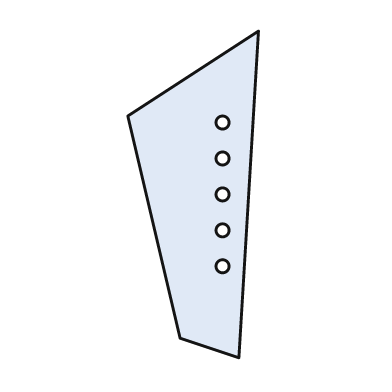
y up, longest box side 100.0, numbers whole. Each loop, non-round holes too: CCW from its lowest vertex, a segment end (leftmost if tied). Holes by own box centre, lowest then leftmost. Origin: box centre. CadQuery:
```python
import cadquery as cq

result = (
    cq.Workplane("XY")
    .moveTo(14.0, -50.0)
    .lineTo(20.0, 50.0)
    .lineTo(-20.0, 24.0)
    .lineTo(-4.0, -44.0)
    .close()
    .moveTo(9.0, -22.0)
    .circle(2.0)
    .moveTo(9.0, -11.0)
    .circle(2.0)
    .moveTo(9.0, 0.0)
    .circle(2.0)
    .moveTo(9.0, 11.0)
    .circle(2.0)
    .moveTo(9.0, 22.0)
    .circle(2.0)
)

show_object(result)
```